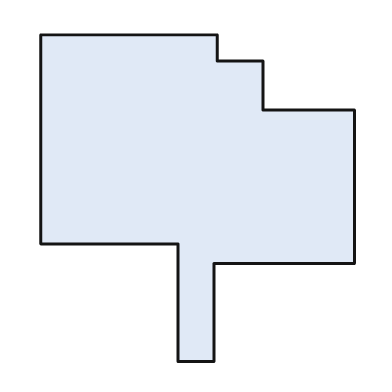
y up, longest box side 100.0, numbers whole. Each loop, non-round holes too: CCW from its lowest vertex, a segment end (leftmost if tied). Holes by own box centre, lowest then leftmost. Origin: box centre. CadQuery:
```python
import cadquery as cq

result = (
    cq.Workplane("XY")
    .moveTo(-6.0, -50.0)
    .lineTo(5.0, -50.0)
    .lineTo(5.0, -20.0)
    .lineTo(48.0, -20.0)
    .lineTo(48.0, 27.0)
    .lineTo(20.0, 27.0)
    .lineTo(20.0, 42.0)
    .lineTo(6.0, 42.0)
    .lineTo(6.0, 50.0)
    .lineTo(-48.0, 50.0)
    .lineTo(-48.0, -14.0)
    .lineTo(-6.0, -14.0)
    .close()
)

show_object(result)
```